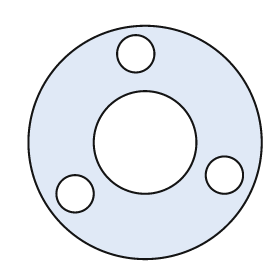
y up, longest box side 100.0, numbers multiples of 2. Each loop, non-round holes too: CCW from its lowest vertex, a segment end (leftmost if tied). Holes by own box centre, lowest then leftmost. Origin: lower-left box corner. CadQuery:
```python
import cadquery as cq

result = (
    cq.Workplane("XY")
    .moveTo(50.0, 50.0)
    .circle(50.0)
    .moveTo(20.0, 28.0)
    .circle(8.0)
    .moveTo(84.0, 36.0)
    .circle(8.0)
    .moveTo(50.0, 50.0)
    .circle(22.0)
    .moveTo(46.0, 88.0)
    .circle(8.0)
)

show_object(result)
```